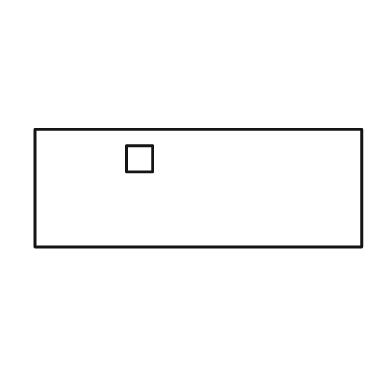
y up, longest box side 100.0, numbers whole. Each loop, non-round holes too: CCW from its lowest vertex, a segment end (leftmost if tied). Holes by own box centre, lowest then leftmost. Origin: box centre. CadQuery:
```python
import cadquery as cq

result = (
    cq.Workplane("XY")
    .moveTo(-50.0, -18.0)
    .lineTo(50.0, -18.0)
    .lineTo(50.0, 18.0)
    .lineTo(-50.0, 18.0)
    .close()
    .moveTo(-22.0, 5.0)
    .lineTo(-14.0, 5.0)
    .lineTo(-14.0, 13.0)
    .lineTo(-22.0, 13.0)
    .close()
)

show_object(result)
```